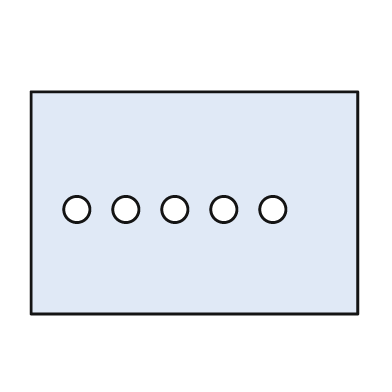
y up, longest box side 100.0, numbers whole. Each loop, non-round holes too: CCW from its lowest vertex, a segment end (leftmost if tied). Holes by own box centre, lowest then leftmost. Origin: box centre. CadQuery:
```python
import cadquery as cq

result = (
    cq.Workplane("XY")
    .moveTo(-50.0, -34.0)
    .lineTo(50.0, -34.0)
    .lineTo(50.0, 34.0)
    .lineTo(-50.0, 34.0)
    .close()
    .moveTo(-36.0, -2.0)
    .circle(4.0)
    .moveTo(-21.0, -2.0)
    .circle(4.0)
    .moveTo(-6.0, -2.0)
    .circle(4.0)
    .moveTo(9.0, -2.0)
    .circle(4.0)
    .moveTo(24.0, -2.0)
    .circle(4.0)
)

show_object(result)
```